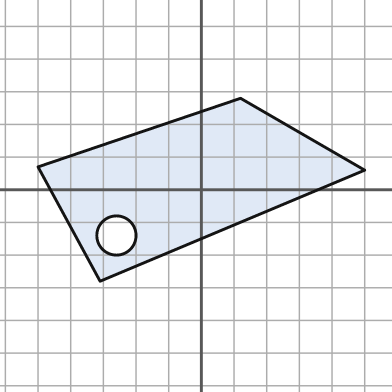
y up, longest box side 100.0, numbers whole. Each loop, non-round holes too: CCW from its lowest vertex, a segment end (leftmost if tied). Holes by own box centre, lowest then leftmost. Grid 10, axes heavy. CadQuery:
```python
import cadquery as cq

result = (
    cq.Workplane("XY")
    .moveTo(-31.0, -28.0)
    .lineTo(50.0, 6.0)
    .lineTo(12.0, 28.0)
    .lineTo(-50.0, 7.0)
    .close()
    .moveTo(-26.0, -14.0)
    .circle(6.0)
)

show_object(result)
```